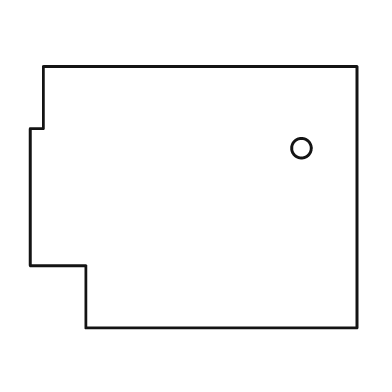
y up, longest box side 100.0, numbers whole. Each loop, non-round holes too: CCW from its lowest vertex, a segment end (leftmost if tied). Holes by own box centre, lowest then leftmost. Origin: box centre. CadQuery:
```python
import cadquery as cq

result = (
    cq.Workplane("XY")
    .moveTo(-33.0, -40.0)
    .lineTo(50.0, -40.0)
    .lineTo(50.0, 40.0)
    .lineTo(-46.0, 40.0)
    .lineTo(-46.0, 21.0)
    .lineTo(-50.0, 21.0)
    .lineTo(-50.0, -21.0)
    .lineTo(-33.0, -21.0)
    .close()
    .moveTo(33.0, 15.0)
    .circle(3.0)
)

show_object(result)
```